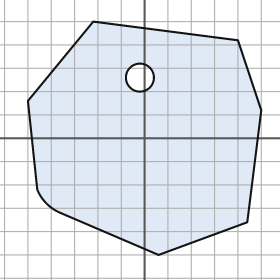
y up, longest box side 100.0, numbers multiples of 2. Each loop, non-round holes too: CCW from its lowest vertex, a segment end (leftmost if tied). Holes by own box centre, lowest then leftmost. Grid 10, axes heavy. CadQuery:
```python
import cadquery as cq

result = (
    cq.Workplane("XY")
    .moveTo(6.0, -50.0)
    .lineTo(44.0, -36.0)
    .lineTo(50.0, 12.0)
    .lineTo(40.0, 42.0)
    .lineTo(-22.0, 50.0)
    .lineTo(-50.0, 16.0)
    .lineTo(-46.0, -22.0)
    .threePointArc((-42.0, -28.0), (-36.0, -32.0))
    .close()
    .moveTo(-2.0, 26.0)
    .circle(6.0)
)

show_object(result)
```